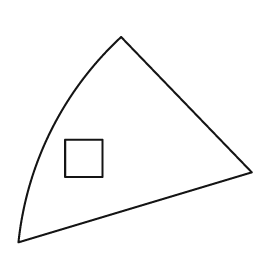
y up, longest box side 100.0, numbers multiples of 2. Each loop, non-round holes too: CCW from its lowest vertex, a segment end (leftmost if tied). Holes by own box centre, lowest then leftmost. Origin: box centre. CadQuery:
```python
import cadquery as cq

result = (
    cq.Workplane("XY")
    .moveTo(-50.0, -44.0)
    .lineTo(50.0, -14.0)
    .lineTo(-6.0, 44.0)
    .threePointArc((-36.0, 4.0), (-50.0, -44.0))
    .close()
    .moveTo(-30.0, -16.0)
    .lineTo(-14.0, -16.0)
    .lineTo(-14.0, 0.0)
    .lineTo(-30.0, 0.0)
    .close()
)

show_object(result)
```